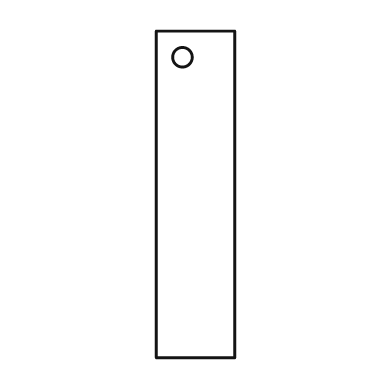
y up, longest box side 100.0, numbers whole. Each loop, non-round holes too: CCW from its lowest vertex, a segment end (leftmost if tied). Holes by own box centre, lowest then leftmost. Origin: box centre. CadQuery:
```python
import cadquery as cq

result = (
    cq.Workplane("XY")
    .moveTo(-12.0, -50.0)
    .lineTo(12.0, -50.0)
    .lineTo(12.0, 50.0)
    .lineTo(-12.0, 50.0)
    .close()
    .moveTo(-4.0, 42.0)
    .circle(3.0)
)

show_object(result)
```